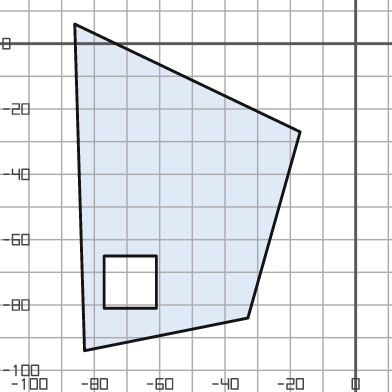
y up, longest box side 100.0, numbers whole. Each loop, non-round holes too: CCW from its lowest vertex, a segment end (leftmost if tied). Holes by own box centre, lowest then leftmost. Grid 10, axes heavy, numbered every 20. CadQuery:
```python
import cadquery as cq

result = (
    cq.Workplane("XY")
    .moveTo(-83.0, -94.0)
    .lineTo(-33.0, -84.0)
    .lineTo(-17.0, -27.0)
    .lineTo(-86.0, 6.0)
    .close()
    .moveTo(-77.0, -81.0)
    .lineTo(-61.0, -81.0)
    .lineTo(-61.0, -65.0)
    .lineTo(-77.0, -65.0)
    .close()
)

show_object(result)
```